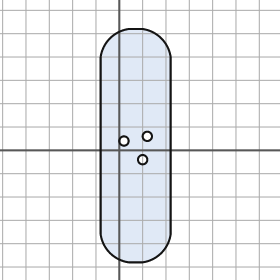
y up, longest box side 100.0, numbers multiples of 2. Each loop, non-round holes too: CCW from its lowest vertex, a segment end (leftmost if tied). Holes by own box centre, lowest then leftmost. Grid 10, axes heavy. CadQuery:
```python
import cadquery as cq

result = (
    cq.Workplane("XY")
    .moveTo(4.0, -48.0)
    .lineTo(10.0, -48.0)
    .threePointArc((18.0, -44.0), (22.0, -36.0))
    .lineTo(22.0, 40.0)
    .threePointArc((18.0, 48.0), (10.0, 52.0))
    .lineTo(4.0, 52.0)
    .threePointArc((-4.0, 48.0), (-8.0, 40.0))
    .lineTo(-8.0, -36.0)
    .threePointArc((-4.0, -44.0), (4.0, -48.0))
    .close()
    .moveTo(10.0, -4.0)
    .circle(2.0)
    .moveTo(2.0, 4.0)
    .circle(2.0)
    .moveTo(12.0, 6.0)
    .circle(2.0)
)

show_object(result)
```